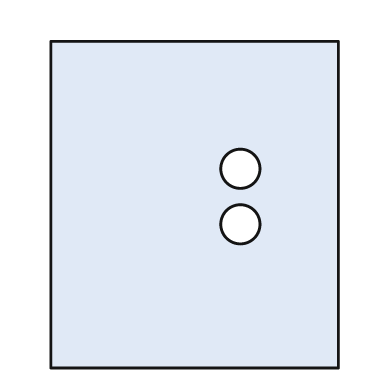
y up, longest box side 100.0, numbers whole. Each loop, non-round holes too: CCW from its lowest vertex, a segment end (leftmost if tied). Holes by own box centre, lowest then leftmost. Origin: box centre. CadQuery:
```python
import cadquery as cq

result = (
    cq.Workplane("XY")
    .moveTo(-44.0, -50.0)
    .lineTo(44.0, -50.0)
    .lineTo(44.0, 50.0)
    .lineTo(-44.0, 50.0)
    .close()
    .moveTo(14.0, -6.0)
    .circle(6.0)
    .moveTo(14.0, 11.0)
    .circle(6.0)
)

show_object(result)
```